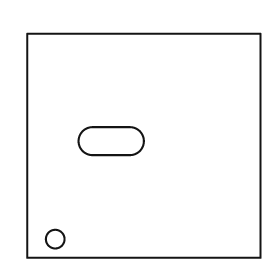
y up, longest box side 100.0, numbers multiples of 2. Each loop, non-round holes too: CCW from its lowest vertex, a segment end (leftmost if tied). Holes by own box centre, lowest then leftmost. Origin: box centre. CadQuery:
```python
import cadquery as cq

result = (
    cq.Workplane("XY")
    .moveTo(-50.0, -48.0)
    .lineTo(50.0, -48.0)
    .lineTo(50.0, 48.0)
    .lineTo(-50.0, 48.0)
    .close()
    .moveTo(-38.0, -40.0)
    .circle(4.0)
    .moveTo(-22.0, -4.0)
    .lineTo(-6.0, -4.0)
    .threePointArc((0.0, 2.0), (-6.0, 8.0))
    .lineTo(-22.0, 8.0)
    .threePointArc((-28.0, 2.0), (-22.0, -4.0))
    .close()
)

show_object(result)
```